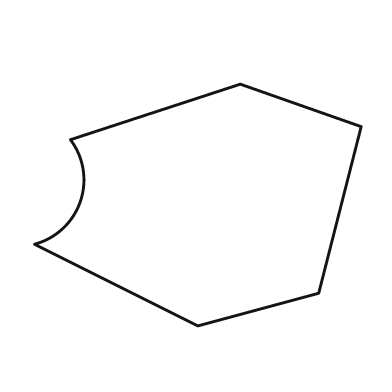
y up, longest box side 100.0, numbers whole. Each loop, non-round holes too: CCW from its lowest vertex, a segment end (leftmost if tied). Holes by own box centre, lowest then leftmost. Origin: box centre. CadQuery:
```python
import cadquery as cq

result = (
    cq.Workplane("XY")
    .moveTo(0.0, -37.0)
    .lineTo(37.0, -27.0)
    .lineTo(50.0, 24.0)
    .lineTo(13.0, 37.0)
    .lineTo(-39.0, 20.0)
    .threePointArc((-36.0, 1.0), (-50.0, -12.0))
    .close()
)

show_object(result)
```